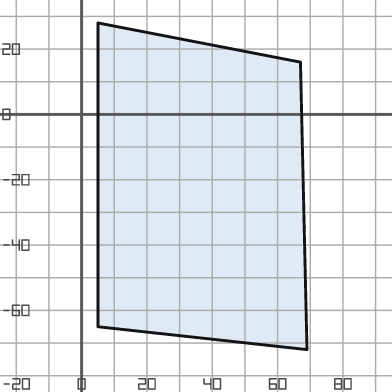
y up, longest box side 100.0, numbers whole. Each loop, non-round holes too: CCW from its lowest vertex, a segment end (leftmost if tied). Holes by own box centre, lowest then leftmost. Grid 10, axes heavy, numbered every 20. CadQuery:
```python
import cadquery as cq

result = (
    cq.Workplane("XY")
    .moveTo(69.0, -72.0)
    .lineTo(67.0, 16.0)
    .lineTo(5.0, 28.0)
    .lineTo(5.0, -65.0)
    .close()
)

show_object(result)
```